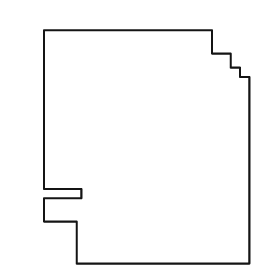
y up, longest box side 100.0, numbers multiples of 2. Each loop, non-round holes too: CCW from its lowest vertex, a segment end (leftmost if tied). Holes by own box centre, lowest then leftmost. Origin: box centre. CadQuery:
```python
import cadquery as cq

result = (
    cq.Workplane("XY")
    .moveTo(-30.0, -50.0)
    .lineTo(44.0, -50.0)
    .lineTo(44.0, 30.0)
    .lineTo(40.0, 30.0)
    .lineTo(40.0, 34.0)
    .lineTo(36.0, 34.0)
    .lineTo(36.0, 40.0)
    .lineTo(28.0, 40.0)
    .lineTo(28.0, 50.0)
    .lineTo(-44.0, 50.0)
    .lineTo(-44.0, -18.0)
    .lineTo(-28.0, -18.0)
    .lineTo(-28.0, -22.0)
    .lineTo(-44.0, -22.0)
    .lineTo(-44.0, -32.0)
    .lineTo(-30.0, -32.0)
    .close()
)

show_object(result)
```